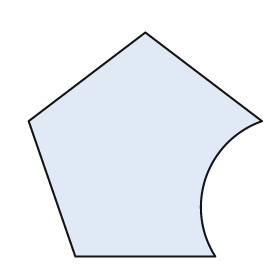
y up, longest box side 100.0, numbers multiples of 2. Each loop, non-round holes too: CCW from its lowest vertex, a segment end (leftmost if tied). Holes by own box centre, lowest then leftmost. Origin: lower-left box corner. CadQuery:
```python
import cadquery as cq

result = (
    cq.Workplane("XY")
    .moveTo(20.0, 0.0)
    .lineTo(80.0, 0.0)
    .threePointArc((76.0, 34.0), (100.0, 58.0))
    .lineTo(50.0, 96.0)
    .lineTo(0.0, 58.0)
    .close()
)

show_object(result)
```